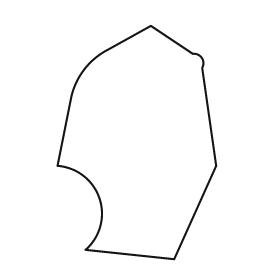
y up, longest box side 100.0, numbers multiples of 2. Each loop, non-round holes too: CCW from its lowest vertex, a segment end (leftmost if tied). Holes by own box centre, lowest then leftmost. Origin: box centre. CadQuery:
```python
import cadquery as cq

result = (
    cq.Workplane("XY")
    .moveTo(16.0, -50.0)
    .lineTo(34.0, -10.0)
    .lineTo(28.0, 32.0)
    .threePointArc((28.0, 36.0), (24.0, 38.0))
    .lineTo(6.0, 50.0)
    .lineTo(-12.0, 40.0)
    .threePointArc((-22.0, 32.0), (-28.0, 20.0))
    .lineTo(-34.0, -10.0)
    .threePointArc((-16.0, -24.0), (-22.0, -46.0))
    .close()
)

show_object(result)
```